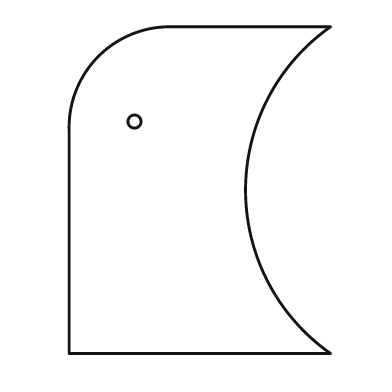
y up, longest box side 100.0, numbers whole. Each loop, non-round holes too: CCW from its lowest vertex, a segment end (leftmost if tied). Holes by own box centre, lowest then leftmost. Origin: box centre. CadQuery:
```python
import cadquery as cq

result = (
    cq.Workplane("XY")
    .moveTo(-40.0, -50.0)
    .lineTo(40.0, -50.0)
    .threePointArc((14.0, 0.0), (40.0, 50.0))
    .lineTo(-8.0, 50.0)
    .threePointArc((-31.0, 41.0), (-40.0, 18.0))
    .close()
    .moveTo(-20.0, 21.0)
    .circle(2.0)
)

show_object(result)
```